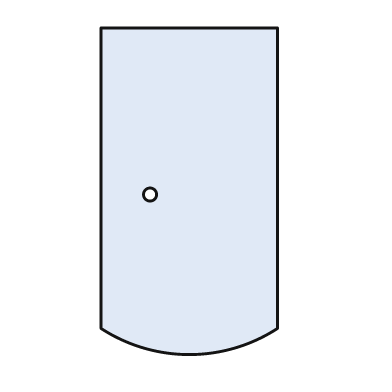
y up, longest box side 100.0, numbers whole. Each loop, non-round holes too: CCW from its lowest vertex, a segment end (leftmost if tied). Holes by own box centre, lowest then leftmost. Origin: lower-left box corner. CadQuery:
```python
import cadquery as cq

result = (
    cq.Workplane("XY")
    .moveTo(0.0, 8.0)
    .threePointArc((27.0, 0.0), (54.0, 8.0))
    .lineTo(54.0, 100.0)
    .lineTo(0.0, 100.0)
    .close()
    .moveTo(15.0, 49.0)
    .circle(2.0)
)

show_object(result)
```